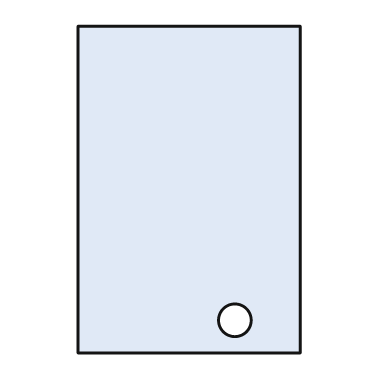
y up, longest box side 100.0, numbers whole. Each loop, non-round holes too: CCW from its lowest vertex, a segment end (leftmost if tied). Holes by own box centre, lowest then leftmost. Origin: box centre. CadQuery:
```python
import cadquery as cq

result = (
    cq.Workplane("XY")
    .moveTo(-34.0, -50.0)
    .lineTo(34.0, -50.0)
    .lineTo(34.0, 50.0)
    .lineTo(-34.0, 50.0)
    .close()
    .moveTo(14.0, -40.0)
    .circle(5.0)
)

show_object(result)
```